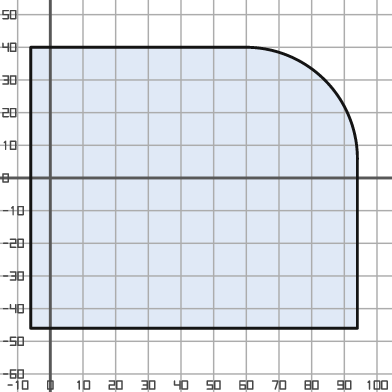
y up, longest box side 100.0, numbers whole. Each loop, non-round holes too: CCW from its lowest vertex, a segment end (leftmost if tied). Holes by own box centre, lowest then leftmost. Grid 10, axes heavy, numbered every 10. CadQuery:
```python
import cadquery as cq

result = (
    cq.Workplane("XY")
    .moveTo(-6.0, -46.0)
    .lineTo(94.0, -46.0)
    .lineTo(94.0, 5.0)
    .threePointArc((84.0, 30.0), (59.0, 40.0))
    .lineTo(-6.0, 40.0)
    .close()
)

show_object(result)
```